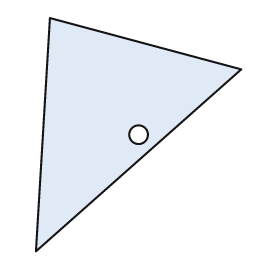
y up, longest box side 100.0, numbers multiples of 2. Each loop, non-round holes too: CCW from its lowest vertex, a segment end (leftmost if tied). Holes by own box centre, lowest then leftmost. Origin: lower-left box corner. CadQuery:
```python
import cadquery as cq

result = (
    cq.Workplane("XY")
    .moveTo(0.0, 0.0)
    .lineTo(88.0, 78.0)
    .lineTo(6.0, 100.0)
    .close()
    .moveTo(44.0, 50.0)
    .circle(4.0)
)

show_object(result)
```